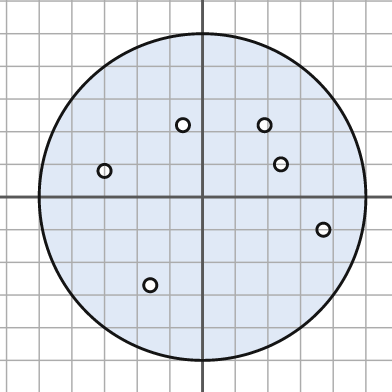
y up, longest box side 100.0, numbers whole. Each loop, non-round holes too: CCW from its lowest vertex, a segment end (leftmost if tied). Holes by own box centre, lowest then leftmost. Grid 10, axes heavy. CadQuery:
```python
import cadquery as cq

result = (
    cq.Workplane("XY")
    .moveTo(0.0, 0.0)
    .circle(50.0)
    .moveTo(-16.0, -27.0)
    .circle(2.0)
    .moveTo(37.0, -10.0)
    .circle(2.0)
    .moveTo(-30.0, 8.0)
    .circle(2.0)
    .moveTo(24.0, 10.0)
    .circle(2.0)
    .moveTo(-6.0, 22.0)
    .circle(2.0)
    .moveTo(19.0, 22.0)
    .circle(2.0)
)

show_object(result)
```